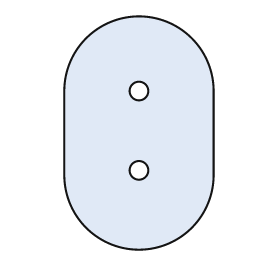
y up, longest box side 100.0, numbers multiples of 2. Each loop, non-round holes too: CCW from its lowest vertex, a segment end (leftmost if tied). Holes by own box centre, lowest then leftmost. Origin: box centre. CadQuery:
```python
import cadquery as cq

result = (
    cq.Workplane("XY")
    .moveTo(-32.0, -18.0)
    .threePointArc((0.0, -50.0), (32.0, -18.0))
    .lineTo(32.0, 18.0)
    .threePointArc((0.0, 50.0), (-32.0, 18.0))
    .close()
    .moveTo(0.0, -16.0)
    .circle(4.0)
    .moveTo(0.0, 18.0)
    .circle(4.0)
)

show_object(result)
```